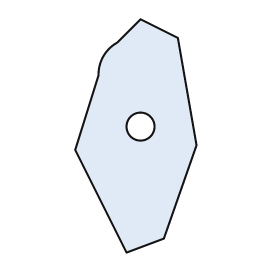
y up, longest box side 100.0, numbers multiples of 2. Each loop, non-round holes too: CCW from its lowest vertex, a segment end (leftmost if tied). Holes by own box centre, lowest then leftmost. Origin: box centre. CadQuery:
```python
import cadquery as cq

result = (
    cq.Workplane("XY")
    .moveTo(-4.0, -50.0)
    .lineTo(12.0, -44.0)
    .lineTo(26.0, -4.0)
    .lineTo(18.0, 42.0)
    .lineTo(2.0, 50.0)
    .lineTo(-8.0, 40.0)
    .threePointArc((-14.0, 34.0), (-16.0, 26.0))
    .lineTo(-26.0, -6.0)
    .close()
    .moveTo(2.0, 4.0)
    .circle(6.0)
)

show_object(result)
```